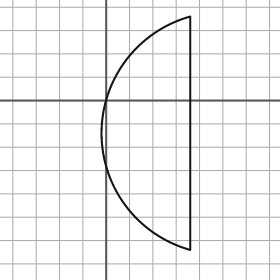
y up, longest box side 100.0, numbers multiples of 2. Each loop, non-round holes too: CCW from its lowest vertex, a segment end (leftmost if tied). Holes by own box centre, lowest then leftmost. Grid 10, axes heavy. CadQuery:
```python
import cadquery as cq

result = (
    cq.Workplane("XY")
    .moveTo(36.0, -64.0)
    .lineTo(36.0, 36.0)
    .threePointArc((-2.0, -14.0), (36.0, -64.0))
    .close()
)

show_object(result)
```